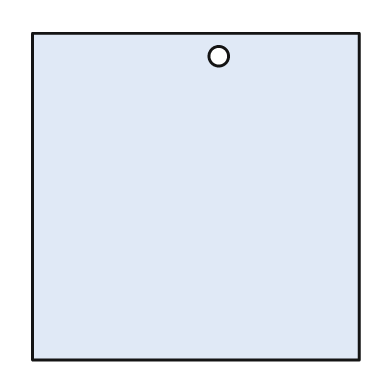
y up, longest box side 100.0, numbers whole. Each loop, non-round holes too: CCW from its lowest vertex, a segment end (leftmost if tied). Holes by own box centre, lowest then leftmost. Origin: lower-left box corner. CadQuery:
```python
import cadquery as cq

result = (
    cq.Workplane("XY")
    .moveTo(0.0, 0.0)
    .lineTo(100.0, 0.0)
    .lineTo(100.0, 100.0)
    .lineTo(0.0, 100.0)
    .close()
    .moveTo(57.0, 93.0)
    .circle(3.0)
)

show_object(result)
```